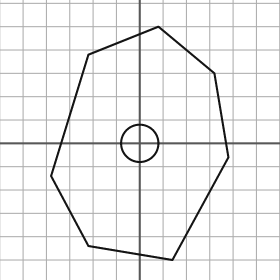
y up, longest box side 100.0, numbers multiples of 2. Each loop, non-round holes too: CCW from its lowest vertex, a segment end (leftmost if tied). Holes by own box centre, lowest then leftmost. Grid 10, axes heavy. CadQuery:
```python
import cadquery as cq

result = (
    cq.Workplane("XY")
    .moveTo(14.0, -50.0)
    .lineTo(38.0, -6.0)
    .lineTo(32.0, 30.0)
    .lineTo(8.0, 50.0)
    .lineTo(-22.0, 38.0)
    .lineTo(-38.0, -14.0)
    .lineTo(-22.0, -44.0)
    .close()
    .moveTo(0.0, 0.0)
    .circle(8.0)
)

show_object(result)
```